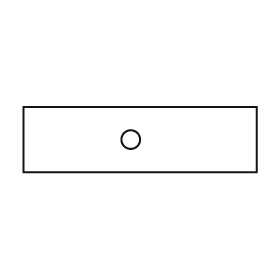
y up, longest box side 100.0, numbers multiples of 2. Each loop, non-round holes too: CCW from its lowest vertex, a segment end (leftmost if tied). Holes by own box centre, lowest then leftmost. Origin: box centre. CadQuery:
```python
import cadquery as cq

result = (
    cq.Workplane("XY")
    .moveTo(-50.0, -14.0)
    .lineTo(50.0, -14.0)
    .lineTo(50.0, 14.0)
    .lineTo(-50.0, 14.0)
    .close()
    .moveTo(-4.0, 0.0)
    .circle(4.0)
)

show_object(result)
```